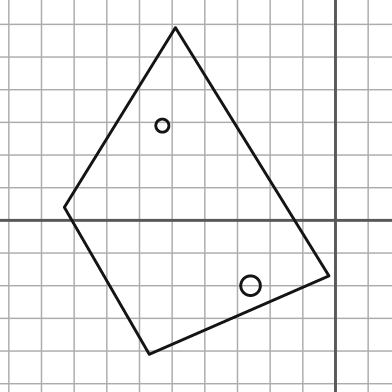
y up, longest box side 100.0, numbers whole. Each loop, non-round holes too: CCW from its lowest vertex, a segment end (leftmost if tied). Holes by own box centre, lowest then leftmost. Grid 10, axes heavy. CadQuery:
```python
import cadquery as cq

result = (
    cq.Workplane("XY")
    .moveTo(-57.0, -41.0)
    .lineTo(-2.0, -17.0)
    .lineTo(-49.0, 59.0)
    .lineTo(-83.0, 4.0)
    .close()
    .moveTo(-26.0, -20.0)
    .circle(3.0)
    .moveTo(-53.0, 29.0)
    .circle(2.0)
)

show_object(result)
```